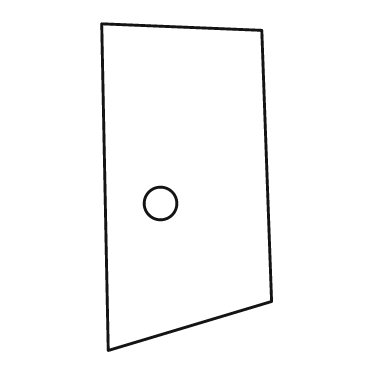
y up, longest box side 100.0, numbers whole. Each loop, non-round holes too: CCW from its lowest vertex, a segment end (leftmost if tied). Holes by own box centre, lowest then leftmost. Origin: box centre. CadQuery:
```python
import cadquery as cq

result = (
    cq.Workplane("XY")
    .moveTo(-24.0, -50.0)
    .lineTo(26.0, -35.0)
    .lineTo(23.0, 48.0)
    .lineTo(-26.0, 50.0)
    .close()
    .moveTo(-8.0, -5.0)
    .circle(5.0)
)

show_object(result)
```